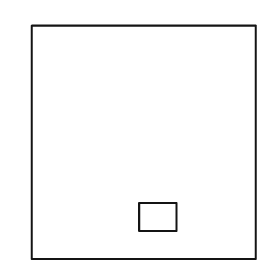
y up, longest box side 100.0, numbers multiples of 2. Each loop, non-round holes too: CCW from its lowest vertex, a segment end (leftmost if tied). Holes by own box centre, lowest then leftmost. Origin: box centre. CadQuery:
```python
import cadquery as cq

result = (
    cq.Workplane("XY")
    .moveTo(-48.0, -50.0)
    .lineTo(48.0, -50.0)
    .lineTo(48.0, 50.0)
    .lineTo(-48.0, 50.0)
    .close()
    .moveTo(-2.0, -38.0)
    .lineTo(14.0, -38.0)
    .lineTo(14.0, -26.0)
    .lineTo(-2.0, -26.0)
    .close()
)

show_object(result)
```